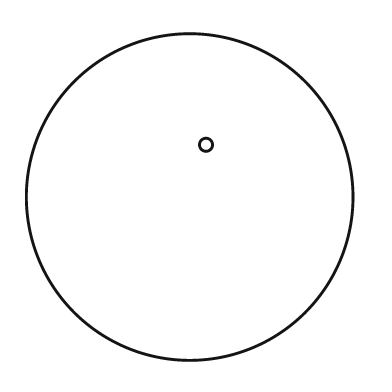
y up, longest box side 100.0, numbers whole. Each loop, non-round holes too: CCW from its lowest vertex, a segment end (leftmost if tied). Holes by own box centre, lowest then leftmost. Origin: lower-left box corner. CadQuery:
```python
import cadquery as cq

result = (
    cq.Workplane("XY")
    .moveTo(50.0, 50.0)
    .circle(50.0)
    .moveTo(55.0, 66.0)
    .circle(2.0)
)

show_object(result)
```